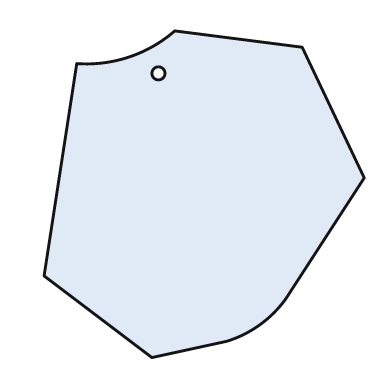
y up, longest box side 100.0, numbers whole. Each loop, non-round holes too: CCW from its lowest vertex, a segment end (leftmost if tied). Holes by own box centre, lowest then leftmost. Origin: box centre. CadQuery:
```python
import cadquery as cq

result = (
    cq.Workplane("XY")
    .moveTo(-16.0, -50.0)
    .lineTo(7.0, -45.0)
    .threePointArc((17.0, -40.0), (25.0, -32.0))
    .lineTo(49.0, 5.0)
    .lineTo(30.0, 45.0)
    .lineTo(-9.0, 50.0)
    .threePointArc((-23.0, 42.0), (-39.0, 40.0))
    .lineTo(-49.0, -25.0)
    .close()
    .moveTo(-14.0, 37.0)
    .circle(2.0)
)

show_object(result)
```